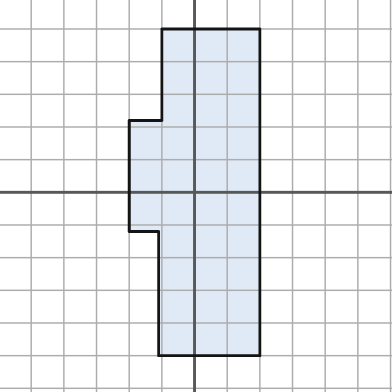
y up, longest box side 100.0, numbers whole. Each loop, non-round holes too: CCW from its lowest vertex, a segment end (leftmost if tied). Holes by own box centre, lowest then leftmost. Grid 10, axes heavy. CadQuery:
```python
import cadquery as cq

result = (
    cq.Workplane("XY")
    .moveTo(-11.0, -50.0)
    .lineTo(20.0, -50.0)
    .lineTo(20.0, 50.0)
    .lineTo(-10.0, 50.0)
    .lineTo(-10.0, 22.0)
    .lineTo(-20.0, 22.0)
    .lineTo(-20.0, -12.0)
    .lineTo(-11.0, -12.0)
    .close()
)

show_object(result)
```